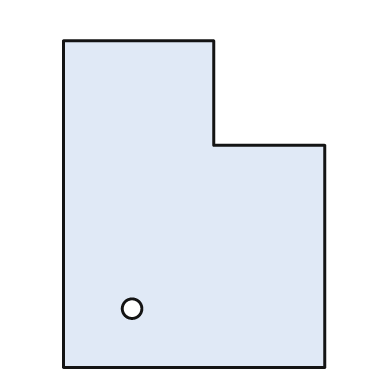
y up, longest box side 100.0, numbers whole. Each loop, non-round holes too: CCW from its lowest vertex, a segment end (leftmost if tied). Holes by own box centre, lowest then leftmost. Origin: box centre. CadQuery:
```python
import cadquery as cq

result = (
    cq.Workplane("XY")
    .moveTo(-40.0, -50.0)
    .lineTo(40.0, -50.0)
    .lineTo(40.0, 18.0)
    .lineTo(6.0, 18.0)
    .lineTo(6.0, 50.0)
    .lineTo(-40.0, 50.0)
    .close()
    .moveTo(-19.0, -32.0)
    .circle(3.0)
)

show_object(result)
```